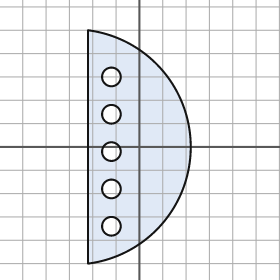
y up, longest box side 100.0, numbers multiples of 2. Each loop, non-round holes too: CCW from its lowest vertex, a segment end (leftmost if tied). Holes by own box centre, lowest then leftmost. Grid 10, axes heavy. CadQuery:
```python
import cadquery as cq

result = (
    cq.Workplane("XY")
    .moveTo(-22.0, -50.0)
    .threePointArc((22.0, 0.0), (-22.0, 50.0))
    .close()
    .moveTo(-12.0, -34.0)
    .circle(4.0)
    .moveTo(-12.0, -18.0)
    .circle(4.0)
    .moveTo(-12.0, -2.0)
    .circle(4.0)
    .moveTo(-12.0, 14.0)
    .circle(4.0)
    .moveTo(-12.0, 30.0)
    .circle(4.0)
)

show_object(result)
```